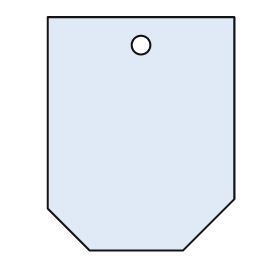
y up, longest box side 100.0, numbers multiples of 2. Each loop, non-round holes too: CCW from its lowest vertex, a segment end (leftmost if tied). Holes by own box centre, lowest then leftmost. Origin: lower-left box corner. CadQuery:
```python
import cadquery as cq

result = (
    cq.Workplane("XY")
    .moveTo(18.0, 0.0)
    .lineTo(58.0, 0.0)
    .lineTo(80.0, 22.0)
    .lineTo(80.0, 100.0)
    .lineTo(0.0, 100.0)
    .lineTo(0.0, 18.0)
    .close()
    .moveTo(40.0, 88.0)
    .circle(4.0)
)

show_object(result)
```